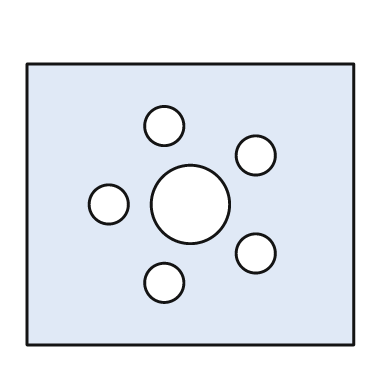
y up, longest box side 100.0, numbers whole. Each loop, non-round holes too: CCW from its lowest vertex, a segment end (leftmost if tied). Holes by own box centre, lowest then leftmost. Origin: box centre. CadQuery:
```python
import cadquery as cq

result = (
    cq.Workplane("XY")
    .moveTo(-50.0, -43.0)
    .lineTo(50.0, -43.0)
    .lineTo(50.0, 43.0)
    .lineTo(-50.0, 43.0)
    .close()
    .moveTo(-8.0, -24.0)
    .circle(6.0)
    .moveTo(20.0, -15.0)
    .circle(6.0)
    .moveTo(-25.0, 0.0)
    .circle(6.0)
    .moveTo(0.0, 0.0)
    .circle(12.0)
    .moveTo(20.0, 15.0)
    .circle(6.0)
    .moveTo(-8.0, 24.0)
    .circle(6.0)
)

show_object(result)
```